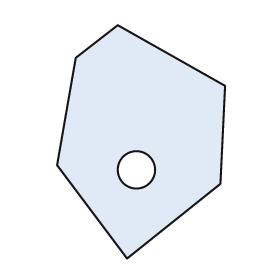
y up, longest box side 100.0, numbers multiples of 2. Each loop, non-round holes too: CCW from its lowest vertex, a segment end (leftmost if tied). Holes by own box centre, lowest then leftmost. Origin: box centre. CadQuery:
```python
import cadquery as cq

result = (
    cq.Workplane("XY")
    .moveTo(-6.0, -50.0)
    .lineTo(34.0, -18.0)
    .lineTo(36.0, 24.0)
    .lineTo(-10.0, 50.0)
    .lineTo(-28.0, 36.0)
    .lineTo(-36.0, -10.0)
    .close()
    .moveTo(-2.0, -12.0)
    .circle(8.0)
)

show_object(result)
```